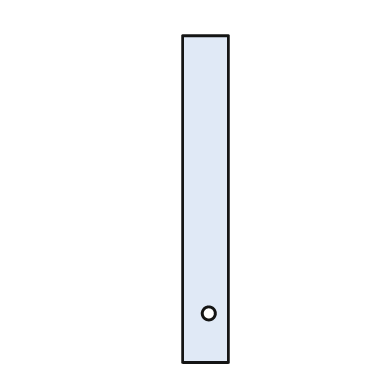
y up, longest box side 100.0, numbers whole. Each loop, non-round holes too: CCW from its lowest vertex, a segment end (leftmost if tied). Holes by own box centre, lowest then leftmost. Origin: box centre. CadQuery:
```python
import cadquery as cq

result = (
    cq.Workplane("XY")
    .moveTo(-7.0, -50.0)
    .lineTo(7.0, -50.0)
    .lineTo(7.0, 50.0)
    .lineTo(-7.0, 50.0)
    .close()
    .moveTo(1.0, -35.0)
    .circle(2.0)
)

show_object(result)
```